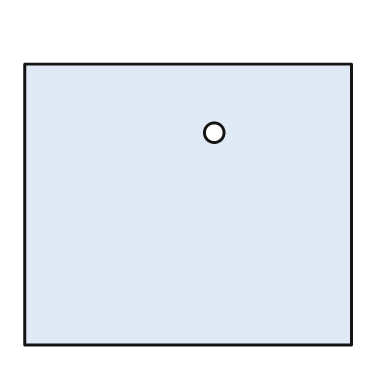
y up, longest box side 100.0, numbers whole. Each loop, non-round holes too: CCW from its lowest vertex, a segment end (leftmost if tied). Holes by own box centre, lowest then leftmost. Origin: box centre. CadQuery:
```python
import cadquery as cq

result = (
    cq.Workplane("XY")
    .moveTo(-50.0, -43.0)
    .lineTo(50.0, -43.0)
    .lineTo(50.0, 43.0)
    .lineTo(-50.0, 43.0)
    .close()
    .moveTo(8.0, 22.0)
    .circle(3.0)
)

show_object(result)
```